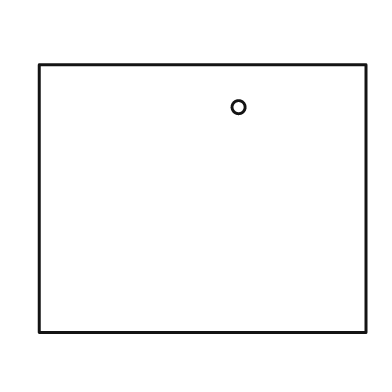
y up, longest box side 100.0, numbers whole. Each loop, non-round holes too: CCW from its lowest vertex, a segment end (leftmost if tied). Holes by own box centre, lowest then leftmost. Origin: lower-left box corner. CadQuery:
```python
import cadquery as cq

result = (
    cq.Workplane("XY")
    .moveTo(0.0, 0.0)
    .lineTo(100.0, 0.0)
    .lineTo(100.0, 82.0)
    .lineTo(0.0, 82.0)
    .close()
    .moveTo(61.0, 69.0)
    .circle(2.0)
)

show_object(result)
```